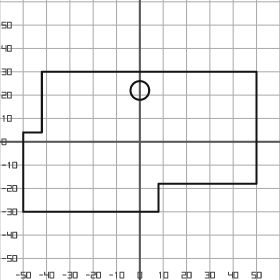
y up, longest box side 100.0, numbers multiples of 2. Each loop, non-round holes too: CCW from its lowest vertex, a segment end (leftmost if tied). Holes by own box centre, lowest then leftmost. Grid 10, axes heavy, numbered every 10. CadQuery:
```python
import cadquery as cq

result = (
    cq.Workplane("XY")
    .moveTo(-50.0, -30.0)
    .lineTo(8.0, -30.0)
    .lineTo(8.0, -18.0)
    .lineTo(50.0, -18.0)
    .lineTo(50.0, 30.0)
    .lineTo(-42.0, 30.0)
    .lineTo(-42.0, 4.0)
    .lineTo(-50.0, 4.0)
    .close()
    .moveTo(0.0, 22.0)
    .circle(4.0)
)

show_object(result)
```